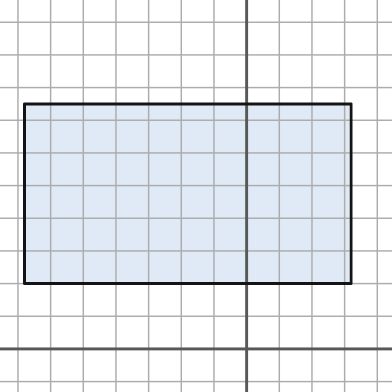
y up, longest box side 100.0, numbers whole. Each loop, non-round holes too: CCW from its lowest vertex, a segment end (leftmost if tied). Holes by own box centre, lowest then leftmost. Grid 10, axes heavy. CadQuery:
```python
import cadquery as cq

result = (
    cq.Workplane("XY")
    .moveTo(-68.0, 20.0)
    .lineTo(32.0, 20.0)
    .lineTo(32.0, 75.0)
    .lineTo(-68.0, 75.0)
    .close()
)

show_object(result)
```